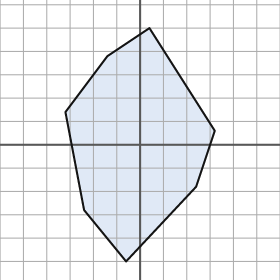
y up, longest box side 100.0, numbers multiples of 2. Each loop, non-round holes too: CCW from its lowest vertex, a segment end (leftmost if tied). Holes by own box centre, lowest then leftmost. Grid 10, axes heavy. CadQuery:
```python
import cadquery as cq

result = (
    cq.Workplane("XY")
    .moveTo(-6.0, -50.0)
    .lineTo(24.0, -18.0)
    .lineTo(32.0, 6.0)
    .lineTo(4.0, 50.0)
    .lineTo(-14.0, 38.0)
    .lineTo(-32.0, 14.0)
    .lineTo(-24.0, -28.0)
    .close()
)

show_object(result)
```